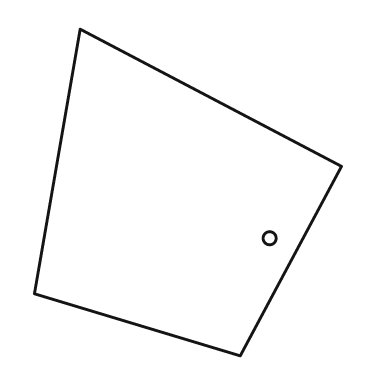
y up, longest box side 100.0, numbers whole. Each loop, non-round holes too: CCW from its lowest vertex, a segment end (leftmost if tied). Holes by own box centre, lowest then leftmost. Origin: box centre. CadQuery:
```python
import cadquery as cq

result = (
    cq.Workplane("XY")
    .moveTo(16.0, -50.0)
    .lineTo(47.0, 8.0)
    .lineTo(-33.0, 50.0)
    .lineTo(-47.0, -31.0)
    .close()
    .moveTo(25.0, -14.0)
    .circle(2.0)
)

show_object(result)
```